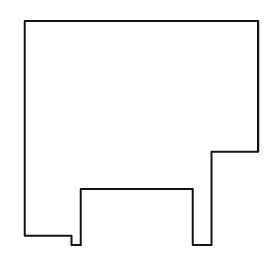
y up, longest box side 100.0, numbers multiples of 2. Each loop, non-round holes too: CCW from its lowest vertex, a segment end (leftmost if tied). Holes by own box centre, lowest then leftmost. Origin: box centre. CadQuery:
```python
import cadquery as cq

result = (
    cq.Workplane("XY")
    .moveTo(-30.0, -48.0)
    .lineTo(-26.0, -48.0)
    .lineTo(-26.0, -24.0)
    .lineTo(22.0, -24.0)
    .lineTo(22.0, -48.0)
    .lineTo(30.0, -48.0)
    .lineTo(30.0, -8.0)
    .lineTo(50.0, -8.0)
    .lineTo(50.0, 48.0)
    .lineTo(-50.0, 48.0)
    .lineTo(-50.0, -44.0)
    .lineTo(-30.0, -44.0)
    .close()
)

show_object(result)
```